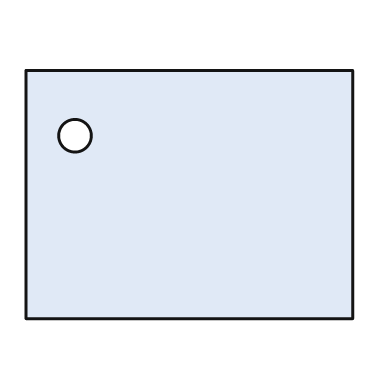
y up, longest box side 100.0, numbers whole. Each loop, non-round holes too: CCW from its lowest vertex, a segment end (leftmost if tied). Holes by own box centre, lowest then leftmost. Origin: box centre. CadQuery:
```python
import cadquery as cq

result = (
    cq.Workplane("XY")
    .moveTo(-50.0, -38.0)
    .lineTo(50.0, -38.0)
    .lineTo(50.0, 38.0)
    .lineTo(-50.0, 38.0)
    .close()
    .moveTo(-35.0, 18.0)
    .circle(5.0)
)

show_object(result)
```